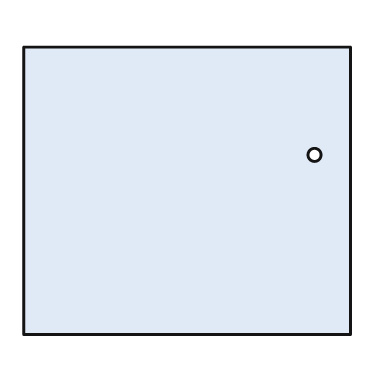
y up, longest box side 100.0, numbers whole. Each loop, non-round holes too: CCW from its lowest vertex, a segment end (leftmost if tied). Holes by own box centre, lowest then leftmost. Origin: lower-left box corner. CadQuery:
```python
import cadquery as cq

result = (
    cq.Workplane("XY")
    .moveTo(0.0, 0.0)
    .lineTo(100.0, 0.0)
    .lineTo(100.0, 88.0)
    .lineTo(0.0, 88.0)
    .close()
    .moveTo(89.0, 55.0)
    .circle(2.0)
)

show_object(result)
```